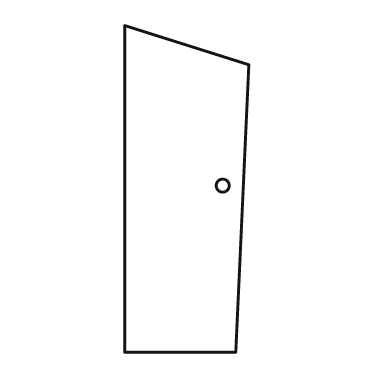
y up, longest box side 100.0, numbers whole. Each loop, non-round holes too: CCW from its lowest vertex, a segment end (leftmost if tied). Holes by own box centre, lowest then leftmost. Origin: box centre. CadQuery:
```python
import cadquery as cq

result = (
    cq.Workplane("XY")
    .moveTo(-19.0, -50.0)
    .lineTo(15.0, -50.0)
    .lineTo(19.0, 38.0)
    .lineTo(-19.0, 50.0)
    .close()
    .moveTo(11.0, 1.0)
    .circle(2.0)
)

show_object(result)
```